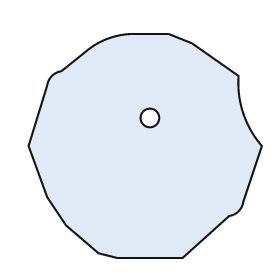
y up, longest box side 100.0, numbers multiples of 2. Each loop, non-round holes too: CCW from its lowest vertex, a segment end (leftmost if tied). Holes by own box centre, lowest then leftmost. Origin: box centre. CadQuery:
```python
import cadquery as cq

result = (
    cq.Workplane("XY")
    .moveTo(-12.0, -48.0)
    .lineTo(16.0, -48.0)
    .lineTo(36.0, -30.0)
    .threePointArc((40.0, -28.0), (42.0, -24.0))
    .lineTo(50.0, 0.0)
    .threePointArc((42.0, 14.0), (40.0, 30.0))
    .lineTo(20.0, 44.0)
    .lineTo(10.0, 48.0)
    .lineTo(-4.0, 48.0)
    .threePointArc((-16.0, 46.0), (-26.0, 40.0))
    .lineTo(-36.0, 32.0)
    .threePointArc((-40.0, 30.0), (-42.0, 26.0))
    .lineTo(-50.0, 0.0)
    .lineTo(-42.0, -22.0)
    .lineTo(-34.0, -34.0)
    .lineTo(-20.0, -46.0)
    .close()
    .moveTo(2.0, 12.0)
    .circle(4.0)
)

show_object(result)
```